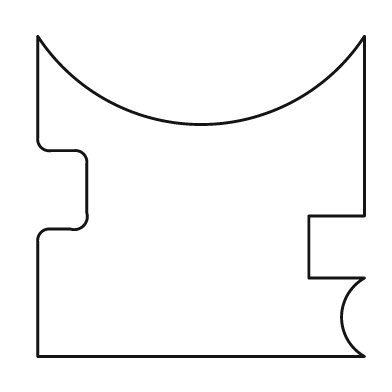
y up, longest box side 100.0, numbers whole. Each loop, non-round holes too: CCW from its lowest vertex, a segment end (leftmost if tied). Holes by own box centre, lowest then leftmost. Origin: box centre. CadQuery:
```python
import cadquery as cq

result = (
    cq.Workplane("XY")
    .moveTo(-50.0, -49.0)
    .lineTo(50.0, -49.0)
    .threePointArc((43.0, -37.0), (50.0, -25.0))
    .lineTo(33.0, -25.0)
    .lineTo(33.0, -6.0)
    .lineTo(50.0, -6.0)
    .lineTo(50.0, 49.0)
    .threePointArc((0.0, 22.0), (-50.0, 49.0))
    .lineTo(-50.0, 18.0)
    .threePointArc((-49.0, 15.0), (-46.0, 14.0))
    .lineTo(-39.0, 14.0)
    .threePointArc((-36.0, 13.0), (-35.0, 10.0))
    .lineTo(-35.0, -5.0)
    .threePointArc((-36.0, -9.0), (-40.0, -10.0))
    .lineTo(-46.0, -10.0)
    .threePointArc((-49.0, -11.0), (-50.0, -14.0))
    .close()
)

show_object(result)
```